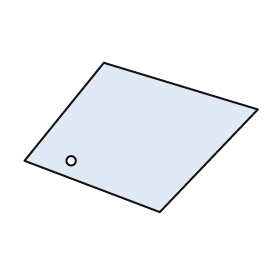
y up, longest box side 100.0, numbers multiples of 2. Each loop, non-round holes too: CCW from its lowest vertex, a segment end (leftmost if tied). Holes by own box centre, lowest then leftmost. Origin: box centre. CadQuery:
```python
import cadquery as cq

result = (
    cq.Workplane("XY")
    .moveTo(8.0, -32.0)
    .lineTo(50.0, 12.0)
    .lineTo(-16.0, 32.0)
    .lineTo(-50.0, -10.0)
    .close()
    .moveTo(-30.0, -10.0)
    .circle(2.0)
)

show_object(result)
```